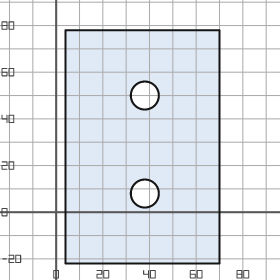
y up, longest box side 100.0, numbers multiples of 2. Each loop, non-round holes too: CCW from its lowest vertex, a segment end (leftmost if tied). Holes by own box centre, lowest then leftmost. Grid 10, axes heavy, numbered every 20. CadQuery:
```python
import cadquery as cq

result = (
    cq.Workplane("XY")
    .moveTo(4.0, -22.0)
    .lineTo(70.0, -22.0)
    .lineTo(70.0, 78.0)
    .lineTo(4.0, 78.0)
    .close()
    .moveTo(38.0, 8.0)
    .circle(6.0)
    .moveTo(38.0, 50.0)
    .circle(6.0)
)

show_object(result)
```